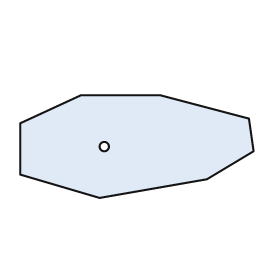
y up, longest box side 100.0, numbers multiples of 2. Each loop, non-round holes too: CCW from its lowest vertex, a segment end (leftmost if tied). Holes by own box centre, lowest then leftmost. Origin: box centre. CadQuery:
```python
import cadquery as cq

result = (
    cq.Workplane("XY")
    .moveTo(-16.0, -22.0)
    .lineTo(30.0, -14.0)
    .lineTo(50.0, -2.0)
    .lineTo(48.0, 12.0)
    .lineTo(10.0, 22.0)
    .lineTo(-24.0, 22.0)
    .lineTo(-50.0, 10.0)
    .lineTo(-50.0, -12.0)
    .close()
    .moveTo(-14.0, 0.0)
    .circle(2.0)
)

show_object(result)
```